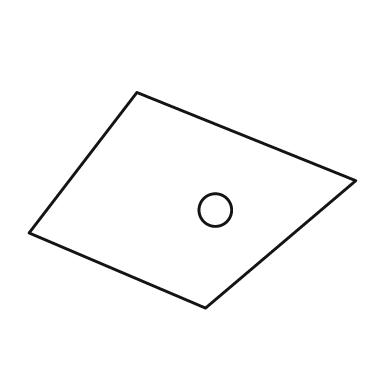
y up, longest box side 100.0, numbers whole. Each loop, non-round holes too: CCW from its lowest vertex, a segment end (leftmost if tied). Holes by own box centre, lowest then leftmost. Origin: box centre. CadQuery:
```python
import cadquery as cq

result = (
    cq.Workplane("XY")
    .moveTo(4.0, -33.0)
    .lineTo(50.0, 6.0)
    .lineTo(-17.0, 33.0)
    .lineTo(-50.0, -10.0)
    .close()
    .moveTo(7.0, -3.0)
    .circle(5.0)
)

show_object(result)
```